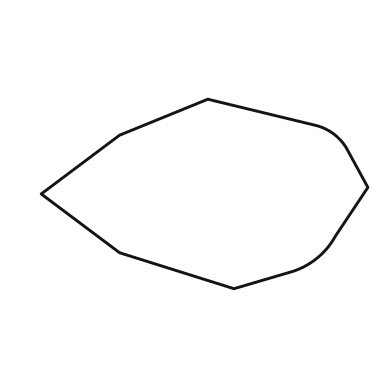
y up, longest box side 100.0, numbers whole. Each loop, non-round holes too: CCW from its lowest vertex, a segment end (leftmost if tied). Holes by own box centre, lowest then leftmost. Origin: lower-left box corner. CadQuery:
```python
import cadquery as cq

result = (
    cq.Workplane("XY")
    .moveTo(59.0, 0.0)
    .lineTo(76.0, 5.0)
    .threePointArc((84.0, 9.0), (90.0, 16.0))
    .lineTo(100.0, 31.0)
    .lineTo(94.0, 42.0)
    .threePointArc((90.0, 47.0), (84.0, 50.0))
    .lineTo(51.0, 58.0)
    .lineTo(24.0, 47.0)
    .lineTo(0.0, 29.0)
    .lineTo(24.0, 11.0)
    .close()
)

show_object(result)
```